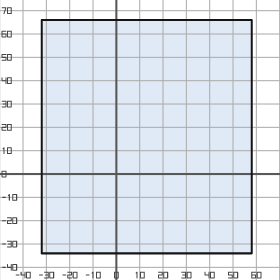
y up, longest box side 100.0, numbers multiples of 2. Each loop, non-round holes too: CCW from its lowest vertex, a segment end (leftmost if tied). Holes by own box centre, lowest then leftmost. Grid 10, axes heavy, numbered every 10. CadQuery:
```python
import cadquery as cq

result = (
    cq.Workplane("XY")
    .moveTo(-32.0, -34.0)
    .lineTo(58.0, -34.0)
    .lineTo(58.0, 66.0)
    .lineTo(-32.0, 66.0)
    .close()
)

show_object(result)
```